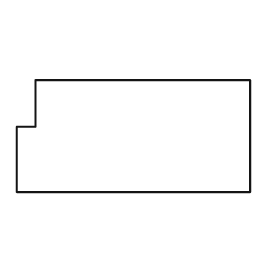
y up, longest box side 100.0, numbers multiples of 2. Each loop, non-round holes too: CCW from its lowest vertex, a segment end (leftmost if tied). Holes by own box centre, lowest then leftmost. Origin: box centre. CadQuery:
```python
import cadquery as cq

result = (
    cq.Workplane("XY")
    .moveTo(-50.0, -24.0)
    .lineTo(50.0, -24.0)
    .lineTo(50.0, 24.0)
    .lineTo(-42.0, 24.0)
    .lineTo(-42.0, 4.0)
    .lineTo(-50.0, 4.0)
    .close()
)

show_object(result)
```